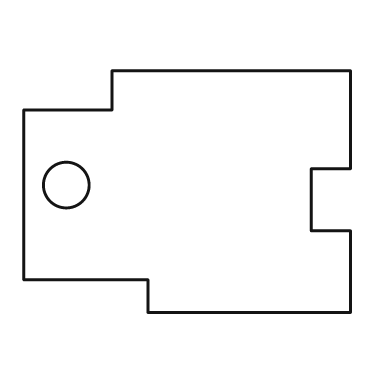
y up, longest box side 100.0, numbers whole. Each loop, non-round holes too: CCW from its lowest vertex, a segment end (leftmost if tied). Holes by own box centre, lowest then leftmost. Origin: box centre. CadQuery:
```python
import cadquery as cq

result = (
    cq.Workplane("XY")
    .moveTo(-12.0, -37.0)
    .lineTo(50.0, -37.0)
    .lineTo(50.0, -12.0)
    .lineTo(38.0, -12.0)
    .lineTo(38.0, 7.0)
    .lineTo(50.0, 7.0)
    .lineTo(50.0, 37.0)
    .lineTo(-23.0, 37.0)
    .lineTo(-23.0, 25.0)
    .lineTo(-50.0, 25.0)
    .lineTo(-50.0, -27.0)
    .lineTo(-12.0, -27.0)
    .close()
    .moveTo(-37.0, 2.0)
    .circle(7.0)
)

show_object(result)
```